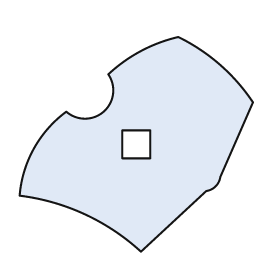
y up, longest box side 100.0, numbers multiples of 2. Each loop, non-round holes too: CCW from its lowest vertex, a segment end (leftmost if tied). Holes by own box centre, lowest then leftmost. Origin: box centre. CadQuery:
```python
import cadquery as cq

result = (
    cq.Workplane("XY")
    .moveTo(2.0, -46.0)
    .lineTo(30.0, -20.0)
    .threePointArc((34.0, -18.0), (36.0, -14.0))
    .lineTo(50.0, 18.0)
    .threePointArc((36.0, 34.0), (18.0, 46.0))
    .threePointArc((2.0, 40.0), (-12.0, 30.0))
    .threePointArc((-14.0, 14.0), (-30.0, 14.0))
    .threePointArc((-44.0, -2.0), (-50.0, -22.0))
    .threePointArc((-22.0, -30.0), (2.0, -46.0))
    .close()
    .moveTo(-6.0, -6.0)
    .lineTo(6.0, -6.0)
    .lineTo(6.0, 6.0)
    .lineTo(-6.0, 6.0)
    .close()
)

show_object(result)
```